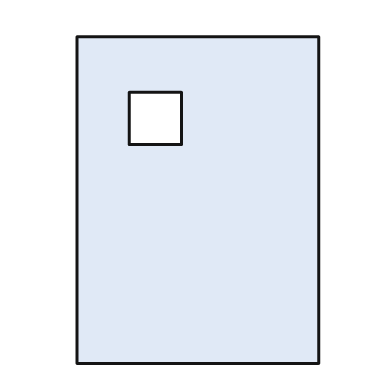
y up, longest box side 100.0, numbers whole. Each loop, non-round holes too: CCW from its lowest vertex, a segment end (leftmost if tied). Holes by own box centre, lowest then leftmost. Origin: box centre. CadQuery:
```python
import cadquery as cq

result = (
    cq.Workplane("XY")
    .moveTo(-37.0, -50.0)
    .lineTo(37.0, -50.0)
    .lineTo(37.0, 50.0)
    .lineTo(-37.0, 50.0)
    .close()
    .moveTo(-21.0, 17.0)
    .lineTo(-5.0, 17.0)
    .lineTo(-5.0, 33.0)
    .lineTo(-21.0, 33.0)
    .close()
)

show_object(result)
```